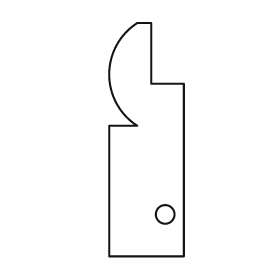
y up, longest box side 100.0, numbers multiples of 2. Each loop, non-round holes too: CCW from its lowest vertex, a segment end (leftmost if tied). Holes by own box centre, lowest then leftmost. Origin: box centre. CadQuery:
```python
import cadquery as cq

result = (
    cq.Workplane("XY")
    .moveTo(-16.0, -50.0)
    .lineTo(16.0, -50.0)
    .lineTo(16.0, 24.0)
    .lineTo(2.0, 24.0)
    .lineTo(2.0, 50.0)
    .lineTo(-4.0, 50.0)
    .threePointArc((-16.0, 28.0), (-4.0, 6.0))
    .lineTo(-16.0, 6.0)
    .close()
    .moveTo(8.0, -32.0)
    .circle(4.0)
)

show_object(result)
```